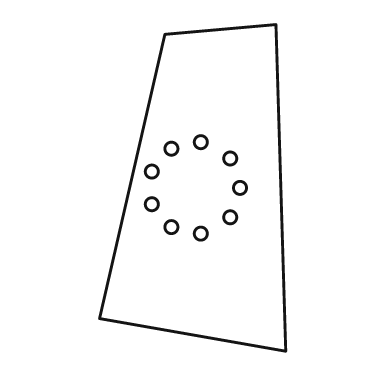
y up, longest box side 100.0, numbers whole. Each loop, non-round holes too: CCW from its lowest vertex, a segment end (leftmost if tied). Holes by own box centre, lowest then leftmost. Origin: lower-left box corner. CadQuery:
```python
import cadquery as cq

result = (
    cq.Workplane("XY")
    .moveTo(57.0, 0.0)
    .lineTo(54.0, 100.0)
    .lineTo(20.0, 97.0)
    .lineTo(0.0, 10.0)
    .close()
    .moveTo(31.0, 36.0)
    .circle(2.0)
    .moveTo(22.0, 38.0)
    .circle(2.0)
    .moveTo(40.0, 41.0)
    .circle(2.0)
    .moveTo(16.0, 45.0)
    .circle(2.0)
    .moveTo(43.0, 50.0)
    .circle(2.0)
    .moveTo(16.0, 55.0)
    .circle(2.0)
    .moveTo(40.0, 59.0)
    .circle(2.0)
    .moveTo(22.0, 62.0)
    .circle(2.0)
    .moveTo(31.0, 64.0)
    .circle(2.0)
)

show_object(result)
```